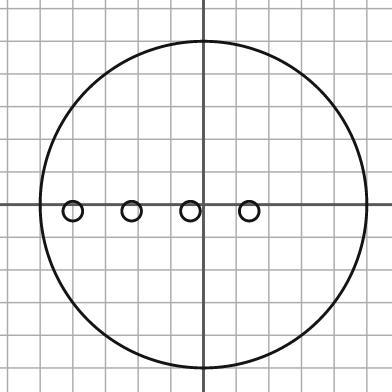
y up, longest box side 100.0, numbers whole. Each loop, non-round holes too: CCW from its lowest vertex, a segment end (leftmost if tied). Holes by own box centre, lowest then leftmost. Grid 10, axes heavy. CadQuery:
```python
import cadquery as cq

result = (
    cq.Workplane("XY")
    .moveTo(0.0, 0.0)
    .circle(50.0)
    .moveTo(-40.0, -2.0)
    .circle(3.0)
    .moveTo(-22.0, -2.0)
    .circle(3.0)
    .moveTo(-4.0, -2.0)
    .circle(3.0)
    .moveTo(14.0, -2.0)
    .circle(3.0)
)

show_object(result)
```